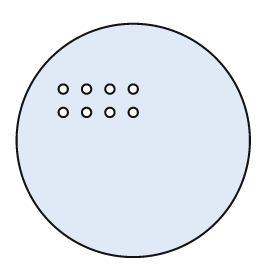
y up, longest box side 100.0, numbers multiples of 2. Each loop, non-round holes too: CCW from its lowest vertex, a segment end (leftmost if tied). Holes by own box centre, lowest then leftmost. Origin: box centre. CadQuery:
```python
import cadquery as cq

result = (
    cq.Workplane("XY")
    .moveTo(0.0, 0.0)
    .circle(50.0)
    .moveTo(-30.0, 12.0)
    .circle(2.0)
    .moveTo(-20.0, 12.0)
    .circle(2.0)
    .moveTo(-10.0, 12.0)
    .circle(2.0)
    .moveTo(0.0, 12.0)
    .circle(2.0)
    .moveTo(-30.0, 22.0)
    .circle(2.0)
    .moveTo(-20.0, 22.0)
    .circle(2.0)
    .moveTo(-10.0, 22.0)
    .circle(2.0)
    .moveTo(0.0, 22.0)
    .circle(2.0)
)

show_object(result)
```